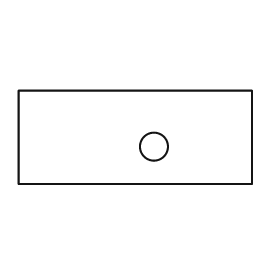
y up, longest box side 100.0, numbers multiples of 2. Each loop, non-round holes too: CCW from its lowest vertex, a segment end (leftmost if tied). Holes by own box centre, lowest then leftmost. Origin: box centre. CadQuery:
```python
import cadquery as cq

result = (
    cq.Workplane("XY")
    .moveTo(-50.0, -20.0)
    .lineTo(50.0, -20.0)
    .lineTo(50.0, 20.0)
    .lineTo(-50.0, 20.0)
    .close()
    .moveTo(8.0, -4.0)
    .circle(6.0)
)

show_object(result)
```